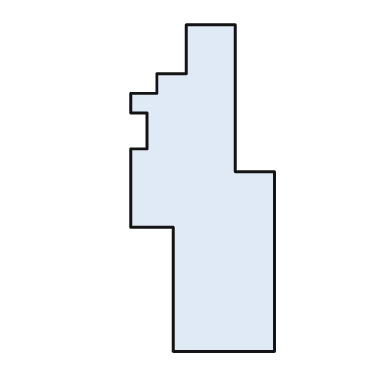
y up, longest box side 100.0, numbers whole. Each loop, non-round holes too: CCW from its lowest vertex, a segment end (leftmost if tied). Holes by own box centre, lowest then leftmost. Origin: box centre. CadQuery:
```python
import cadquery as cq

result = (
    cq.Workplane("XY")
    .moveTo(-9.0, -50.0)
    .lineTo(22.0, -50.0)
    .lineTo(22.0, 5.0)
    .lineTo(10.0, 5.0)
    .lineTo(10.0, 50.0)
    .lineTo(-5.0, 50.0)
    .lineTo(-5.0, 35.0)
    .lineTo(-14.0, 35.0)
    .lineTo(-14.0, 29.0)
    .lineTo(-22.0, 29.0)
    .lineTo(-22.0, 23.0)
    .lineTo(-17.0, 23.0)
    .lineTo(-17.0, 12.0)
    .lineTo(-22.0, 12.0)
    .lineTo(-22.0, -12.0)
    .lineTo(-9.0, -12.0)
    .close()
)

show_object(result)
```